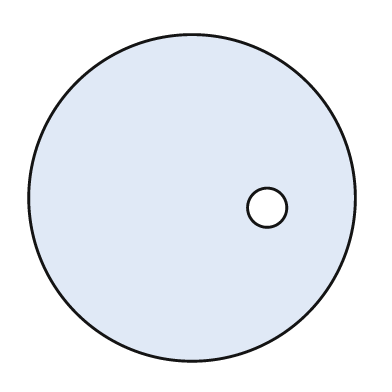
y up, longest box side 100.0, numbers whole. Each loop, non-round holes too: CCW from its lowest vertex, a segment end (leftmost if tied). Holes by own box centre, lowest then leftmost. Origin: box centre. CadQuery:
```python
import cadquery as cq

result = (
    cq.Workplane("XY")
    .moveTo(0.0, 0.0)
    .circle(50.0)
    .moveTo(23.0, -3.0)
    .circle(6.0)
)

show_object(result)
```